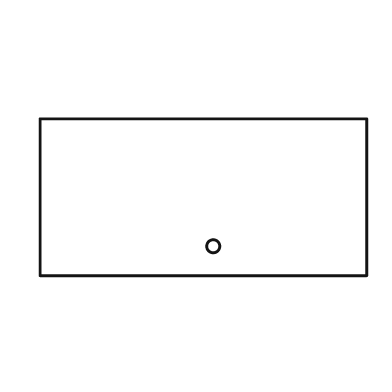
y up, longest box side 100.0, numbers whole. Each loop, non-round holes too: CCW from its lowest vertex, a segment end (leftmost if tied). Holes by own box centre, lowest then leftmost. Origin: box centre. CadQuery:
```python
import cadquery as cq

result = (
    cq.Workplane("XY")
    .moveTo(-50.0, -24.0)
    .lineTo(50.0, -24.0)
    .lineTo(50.0, 24.0)
    .lineTo(-50.0, 24.0)
    .close()
    .moveTo(3.0, -15.0)
    .circle(2.0)
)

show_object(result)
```